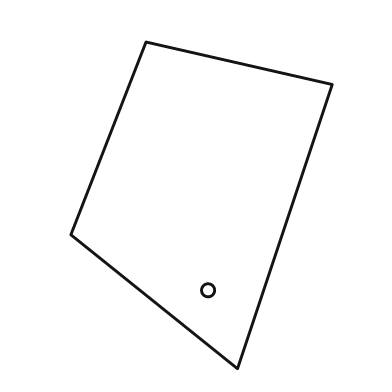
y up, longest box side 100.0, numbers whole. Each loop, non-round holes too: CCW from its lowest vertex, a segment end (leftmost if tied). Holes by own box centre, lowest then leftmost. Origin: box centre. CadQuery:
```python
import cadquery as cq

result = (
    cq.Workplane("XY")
    .moveTo(11.0, -50.0)
    .lineTo(40.0, 37.0)
    .lineTo(-17.0, 50.0)
    .lineTo(-40.0, -9.0)
    .close()
    .moveTo(2.0, -26.0)
    .circle(2.0)
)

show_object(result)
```